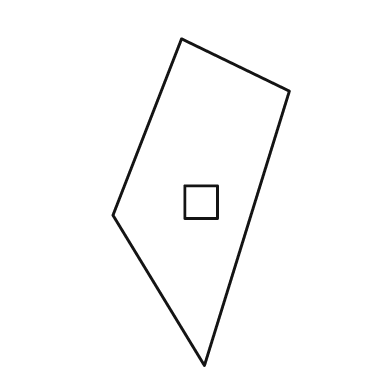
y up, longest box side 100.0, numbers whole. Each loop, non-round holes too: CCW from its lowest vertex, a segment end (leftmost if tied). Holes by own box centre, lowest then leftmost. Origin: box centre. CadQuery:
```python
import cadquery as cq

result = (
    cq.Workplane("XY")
    .moveTo(1.0, -50.0)
    .lineTo(27.0, 34.0)
    .lineTo(-6.0, 50.0)
    .lineTo(-27.0, -4.0)
    .close()
    .moveTo(-5.0, -5.0)
    .lineTo(5.0, -5.0)
    .lineTo(5.0, 5.0)
    .lineTo(-5.0, 5.0)
    .close()
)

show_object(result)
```